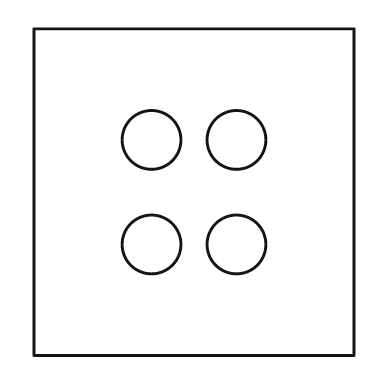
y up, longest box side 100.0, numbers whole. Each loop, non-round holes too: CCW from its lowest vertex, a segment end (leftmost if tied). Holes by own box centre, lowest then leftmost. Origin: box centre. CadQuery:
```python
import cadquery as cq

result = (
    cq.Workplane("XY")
    .moveTo(-49.0, -50.0)
    .lineTo(49.0, -50.0)
    .lineTo(49.0, 50.0)
    .lineTo(-49.0, 50.0)
    .close()
    .moveTo(-13.0, -16.0)
    .circle(9.0)
    .moveTo(13.0, -16.0)
    .circle(9.0)
    .moveTo(-13.0, 16.0)
    .circle(9.0)
    .moveTo(13.0, 16.0)
    .circle(9.0)
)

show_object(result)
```